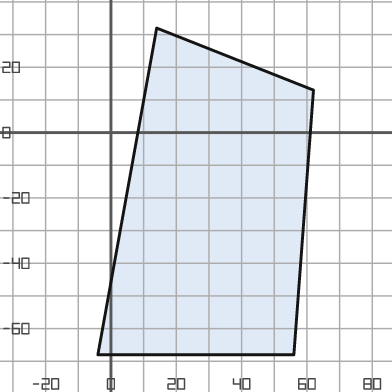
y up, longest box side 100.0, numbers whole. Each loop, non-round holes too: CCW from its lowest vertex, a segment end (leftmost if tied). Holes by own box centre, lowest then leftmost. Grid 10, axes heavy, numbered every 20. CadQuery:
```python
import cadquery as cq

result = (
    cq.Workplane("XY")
    .moveTo(-4.0, -68.0)
    .lineTo(56.0, -68.0)
    .lineTo(62.0, 13.0)
    .lineTo(14.0, 32.0)
    .close()
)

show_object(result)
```